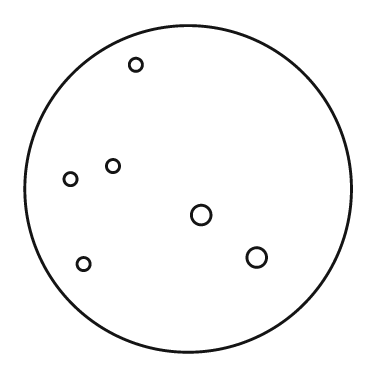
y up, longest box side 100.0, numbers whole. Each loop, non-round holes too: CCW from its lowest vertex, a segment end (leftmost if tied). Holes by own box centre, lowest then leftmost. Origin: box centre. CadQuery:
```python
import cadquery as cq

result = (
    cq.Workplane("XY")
    .moveTo(0.0, 0.0)
    .circle(50.0)
    .moveTo(-32.0, -23.0)
    .circle(2.0)
    .moveTo(21.0, -21.0)
    .circle(3.0)
    .moveTo(4.0, -8.0)
    .circle(3.0)
    .moveTo(-36.0, 3.0)
    .circle(2.0)
    .moveTo(-23.0, 7.0)
    .circle(2.0)
    .moveTo(-16.0, 38.0)
    .circle(2.0)
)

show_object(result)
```